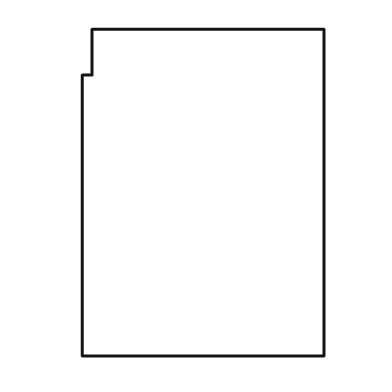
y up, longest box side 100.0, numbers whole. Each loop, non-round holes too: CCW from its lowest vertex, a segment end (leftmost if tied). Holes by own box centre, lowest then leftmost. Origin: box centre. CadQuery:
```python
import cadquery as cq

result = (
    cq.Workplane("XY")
    .moveTo(-37.0, -50.0)
    .lineTo(37.0, -50.0)
    .lineTo(37.0, 50.0)
    .lineTo(-34.0, 50.0)
    .lineTo(-34.0, 36.0)
    .lineTo(-37.0, 36.0)
    .close()
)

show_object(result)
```